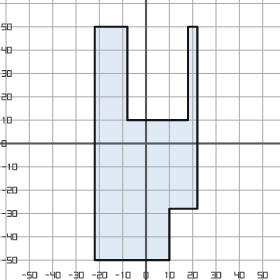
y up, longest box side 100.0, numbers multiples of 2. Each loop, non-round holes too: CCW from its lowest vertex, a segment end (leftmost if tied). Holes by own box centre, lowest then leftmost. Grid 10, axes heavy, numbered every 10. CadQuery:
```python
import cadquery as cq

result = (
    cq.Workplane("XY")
    .moveTo(-22.0, -50.0)
    .lineTo(10.0, -50.0)
    .lineTo(10.0, -28.0)
    .lineTo(22.0, -28.0)
    .lineTo(22.0, 50.0)
    .lineTo(18.0, 50.0)
    .lineTo(18.0, 10.0)
    .lineTo(-8.0, 10.0)
    .lineTo(-8.0, 50.0)
    .lineTo(-22.0, 50.0)
    .close()
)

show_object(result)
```